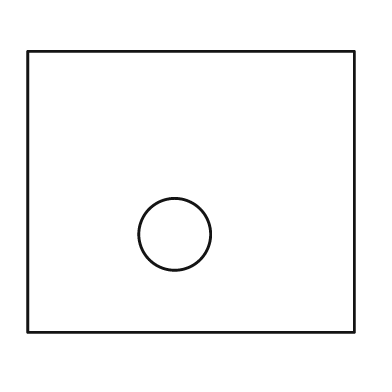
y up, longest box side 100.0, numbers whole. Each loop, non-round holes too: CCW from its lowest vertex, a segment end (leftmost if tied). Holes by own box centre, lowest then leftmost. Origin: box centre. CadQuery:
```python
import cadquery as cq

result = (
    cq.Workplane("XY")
    .moveTo(-50.0, -43.0)
    .lineTo(50.0, -43.0)
    .lineTo(50.0, 43.0)
    .lineTo(-50.0, 43.0)
    .close()
    .moveTo(-5.0, -13.0)
    .circle(11.0)
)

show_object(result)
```